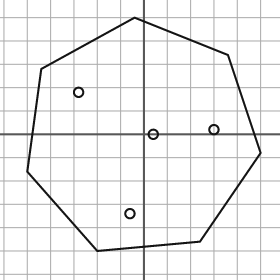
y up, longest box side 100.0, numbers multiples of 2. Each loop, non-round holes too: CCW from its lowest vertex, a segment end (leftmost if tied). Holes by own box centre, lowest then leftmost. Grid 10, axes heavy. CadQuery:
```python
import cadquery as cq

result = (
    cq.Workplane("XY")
    .moveTo(-20.0, -50.0)
    .lineTo(24.0, -46.0)
    .lineTo(50.0, -8.0)
    .lineTo(36.0, 34.0)
    .lineTo(-4.0, 50.0)
    .lineTo(-44.0, 28.0)
    .lineTo(-50.0, -16.0)
    .close()
    .moveTo(-6.0, -34.0)
    .circle(2.0)
    .moveTo(4.0, 0.0)
    .circle(2.0)
    .moveTo(30.0, 2.0)
    .circle(2.0)
    .moveTo(-28.0, 18.0)
    .circle(2.0)
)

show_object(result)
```